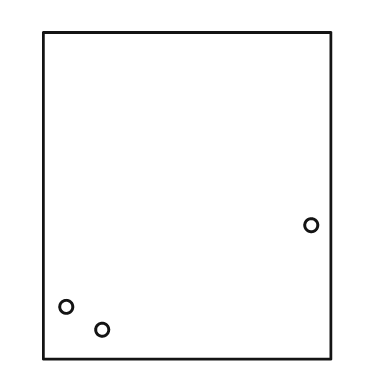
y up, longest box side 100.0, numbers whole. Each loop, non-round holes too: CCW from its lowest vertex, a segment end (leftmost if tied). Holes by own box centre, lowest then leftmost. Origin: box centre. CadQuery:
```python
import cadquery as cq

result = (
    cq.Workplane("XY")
    .moveTo(-44.0, -50.0)
    .lineTo(44.0, -50.0)
    .lineTo(44.0, 50.0)
    .lineTo(-44.0, 50.0)
    .close()
    .moveTo(-26.0, -41.0)
    .circle(2.0)
    .moveTo(-37.0, -34.0)
    .circle(2.0)
    .moveTo(38.0, -9.0)
    .circle(2.0)
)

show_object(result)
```